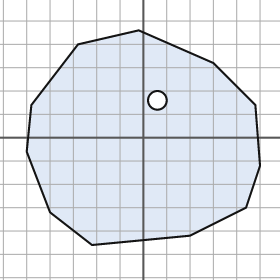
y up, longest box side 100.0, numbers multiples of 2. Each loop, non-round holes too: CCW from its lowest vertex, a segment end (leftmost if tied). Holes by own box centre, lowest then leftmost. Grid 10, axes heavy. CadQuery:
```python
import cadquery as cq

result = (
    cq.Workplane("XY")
    .moveTo(-22.0, -46.0)
    .lineTo(20.0, -42.0)
    .lineTo(44.0, -30.0)
    .lineTo(50.0, -12.0)
    .lineTo(48.0, 14.0)
    .lineTo(30.0, 32.0)
    .lineTo(-2.0, 46.0)
    .lineTo(-28.0, 40.0)
    .lineTo(-48.0, 14.0)
    .lineTo(-50.0, -6.0)
    .lineTo(-40.0, -32.0)
    .close()
    .moveTo(6.0, 16.0)
    .circle(4.0)
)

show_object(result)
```